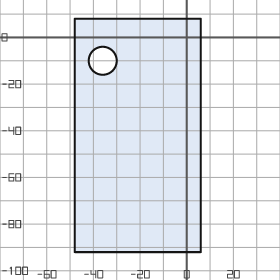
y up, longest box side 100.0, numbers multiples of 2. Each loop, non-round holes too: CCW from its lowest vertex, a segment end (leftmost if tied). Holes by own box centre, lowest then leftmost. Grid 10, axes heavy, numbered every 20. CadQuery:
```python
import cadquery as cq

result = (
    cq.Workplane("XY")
    .moveTo(-48.0, -92.0)
    .lineTo(6.0, -92.0)
    .lineTo(6.0, 8.0)
    .lineTo(-48.0, 8.0)
    .close()
    .moveTo(-36.0, -10.0)
    .circle(6.0)
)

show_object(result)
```